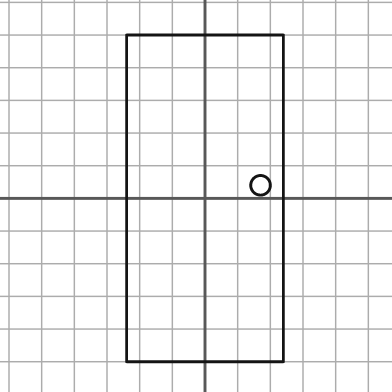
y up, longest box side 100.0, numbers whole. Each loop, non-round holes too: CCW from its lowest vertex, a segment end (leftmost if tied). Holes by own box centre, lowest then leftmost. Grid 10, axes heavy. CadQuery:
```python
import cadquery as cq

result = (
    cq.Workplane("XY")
    .moveTo(-24.0, -50.0)
    .lineTo(24.0, -50.0)
    .lineTo(24.0, 50.0)
    .lineTo(-24.0, 50.0)
    .close()
    .moveTo(17.0, 4.0)
    .circle(3.0)
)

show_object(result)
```